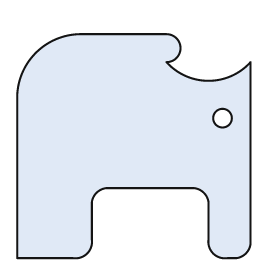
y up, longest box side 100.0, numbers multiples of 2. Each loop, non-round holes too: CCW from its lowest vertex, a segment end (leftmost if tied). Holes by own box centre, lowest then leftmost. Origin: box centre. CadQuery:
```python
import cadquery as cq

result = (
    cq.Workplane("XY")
    .moveTo(-50.0, -48.0)
    .lineTo(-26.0, -48.0)
    .threePointArc((-20.0, -46.0), (-18.0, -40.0))
    .lineTo(-18.0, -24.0)
    .threePointArc((-16.0, -20.0), (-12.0, -18.0))
    .lineTo(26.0, -18.0)
    .threePointArc((30.0, -20.0), (32.0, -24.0))
    .lineTo(32.0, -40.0)
    .threePointArc((34.0, -46.0), (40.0, -48.0))
    .lineTo(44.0, -48.0)
    .threePointArc((48.0, -46.0), (50.0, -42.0))
    .lineTo(50.0, 36.0)
    .threePointArc((32.0, 28.0), (14.0, 36.0))
    .threePointArc((20.0, 42.0), (14.0, 48.0))
    .lineTo(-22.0, 48.0)
    .threePointArc((-42.0, 40.0), (-50.0, 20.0))
    .close()
    .moveTo(38.0, 12.0)
    .circle(4.0)
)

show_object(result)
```